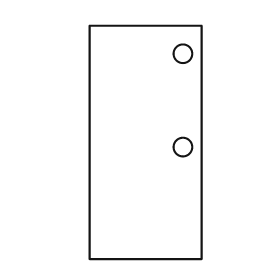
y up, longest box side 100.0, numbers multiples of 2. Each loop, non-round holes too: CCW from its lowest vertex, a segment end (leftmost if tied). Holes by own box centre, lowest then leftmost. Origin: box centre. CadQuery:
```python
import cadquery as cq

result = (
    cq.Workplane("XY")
    .moveTo(-24.0, -50.0)
    .lineTo(24.0, -50.0)
    .lineTo(24.0, 50.0)
    .lineTo(-24.0, 50.0)
    .close()
    .moveTo(16.0, -2.0)
    .circle(4.0)
    .moveTo(16.0, 38.0)
    .circle(4.0)
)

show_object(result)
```